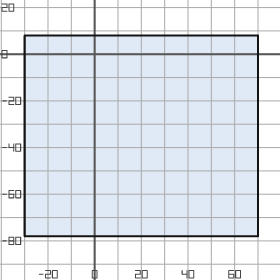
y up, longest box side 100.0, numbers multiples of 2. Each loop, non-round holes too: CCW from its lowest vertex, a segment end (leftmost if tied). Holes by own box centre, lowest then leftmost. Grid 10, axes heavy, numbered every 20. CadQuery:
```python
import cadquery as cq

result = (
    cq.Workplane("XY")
    .moveTo(-30.0, -78.0)
    .lineTo(70.0, -78.0)
    .lineTo(70.0, 8.0)
    .lineTo(-30.0, 8.0)
    .close()
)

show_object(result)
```